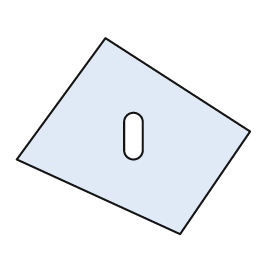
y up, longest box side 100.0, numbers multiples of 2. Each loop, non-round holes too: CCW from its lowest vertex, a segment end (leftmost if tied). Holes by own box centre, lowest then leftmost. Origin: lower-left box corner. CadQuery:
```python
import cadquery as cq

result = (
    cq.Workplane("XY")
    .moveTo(70.0, 0.0)
    .lineTo(100.0, 44.0)
    .lineTo(38.0, 84.0)
    .lineTo(0.0, 32.0)
    .close()
    .moveTo(46.0, 36.0)
    .threePointArc((50.0, 32.0), (54.0, 36.0))
    .lineTo(54.0, 48.0)
    .threePointArc((50.0, 52.0), (46.0, 48.0))
    .close()
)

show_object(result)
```